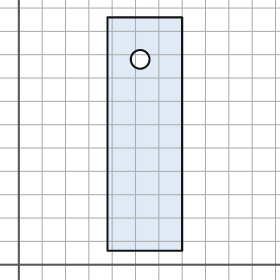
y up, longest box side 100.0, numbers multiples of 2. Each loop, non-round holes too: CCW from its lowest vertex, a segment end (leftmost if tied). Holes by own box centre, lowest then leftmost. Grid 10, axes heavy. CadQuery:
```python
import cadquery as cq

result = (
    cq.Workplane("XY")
    .moveTo(38.0, 6.0)
    .lineTo(70.0, 6.0)
    .lineTo(70.0, 106.0)
    .lineTo(38.0, 106.0)
    .close()
    .moveTo(52.0, 88.0)
    .circle(4.0)
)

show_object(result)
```